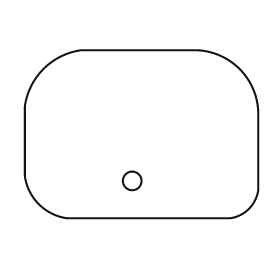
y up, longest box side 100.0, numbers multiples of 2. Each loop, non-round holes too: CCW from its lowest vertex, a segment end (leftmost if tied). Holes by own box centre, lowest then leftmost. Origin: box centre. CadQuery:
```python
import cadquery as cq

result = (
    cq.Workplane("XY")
    .moveTo(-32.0, -36.0)
    .lineTo(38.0, -36.0)
    .threePointArc((46.0, -32.0), (50.0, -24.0))
    .lineTo(50.0, 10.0)
    .threePointArc((42.0, 28.0), (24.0, 36.0))
    .lineTo(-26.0, 36.0)
    .threePointArc((-42.0, 28.0), (-50.0, 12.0))
    .lineTo(-50.0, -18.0)
    .threePointArc((-44.0, -30.0), (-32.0, -36.0))
    .close()
    .moveTo(-4.0, -20.0)
    .circle(4.0)
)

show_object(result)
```